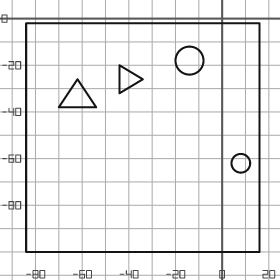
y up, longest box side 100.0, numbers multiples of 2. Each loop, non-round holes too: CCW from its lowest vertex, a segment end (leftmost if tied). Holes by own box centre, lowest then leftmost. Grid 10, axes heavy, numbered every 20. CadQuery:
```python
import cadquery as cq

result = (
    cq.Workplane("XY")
    .moveTo(-84.0, -100.0)
    .lineTo(16.0, -100.0)
    .lineTo(16.0, -2.0)
    .lineTo(-84.0, -2.0)
    .close()
    .moveTo(8.0, -62.0)
    .circle(4.0)
    .moveTo(-70.0, -38.0)
    .lineTo(-54.0, -38.0)
    .lineTo(-62.0, -26.0)
    .close()
    .moveTo(-44.0, -32.0)
    .lineTo(-34.0, -26.0)
    .lineTo(-44.0, -20.0)
    .close()
    .moveTo(-14.0, -18.0)
    .circle(6.0)
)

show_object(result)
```